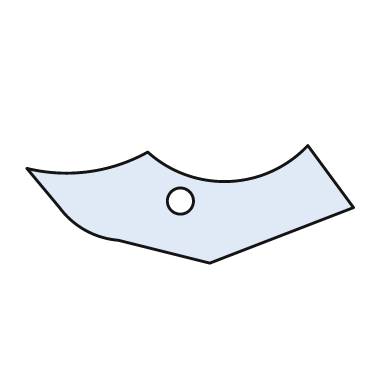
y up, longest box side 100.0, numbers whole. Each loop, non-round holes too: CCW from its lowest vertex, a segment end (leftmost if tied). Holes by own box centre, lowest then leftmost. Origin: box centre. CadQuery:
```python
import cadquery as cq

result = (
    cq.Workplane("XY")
    .moveTo(6.0, -18.0)
    .lineTo(50.0, -1.0)
    .lineTo(36.0, 18.0)
    .threePointArc((12.0, 7.0), (-13.0, 16.0))
    .threePointArc((-31.0, 10.0), (-50.0, 11.0))
    .lineTo(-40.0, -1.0)
    .threePointArc((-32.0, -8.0), (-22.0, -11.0))
    .close()
    .moveTo(-3.0, 1.0)
    .circle(4.0)
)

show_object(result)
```